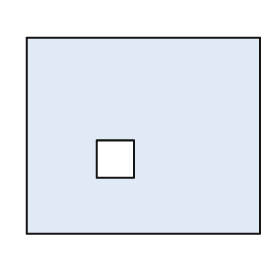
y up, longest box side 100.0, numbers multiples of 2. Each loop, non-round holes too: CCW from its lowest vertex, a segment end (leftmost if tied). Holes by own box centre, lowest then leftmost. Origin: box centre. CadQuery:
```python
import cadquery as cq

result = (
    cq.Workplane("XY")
    .moveTo(-50.0, -42.0)
    .lineTo(50.0, -42.0)
    .lineTo(50.0, 42.0)
    .lineTo(-50.0, 42.0)
    .close()
    .moveTo(-20.0, -18.0)
    .lineTo(-4.0, -18.0)
    .lineTo(-4.0, -2.0)
    .lineTo(-20.0, -2.0)
    .close()
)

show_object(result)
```